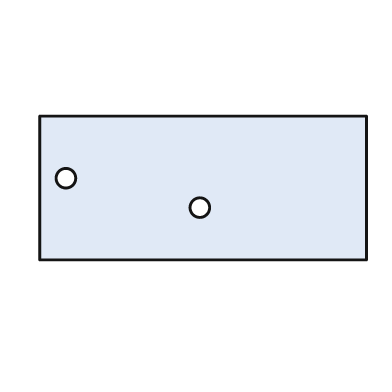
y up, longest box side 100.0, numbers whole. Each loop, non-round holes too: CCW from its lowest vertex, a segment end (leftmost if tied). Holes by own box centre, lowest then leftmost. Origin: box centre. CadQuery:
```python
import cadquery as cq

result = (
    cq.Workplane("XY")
    .moveTo(-50.0, -22.0)
    .lineTo(50.0, -22.0)
    .lineTo(50.0, 22.0)
    .lineTo(-50.0, 22.0)
    .close()
    .moveTo(-1.0, -6.0)
    .circle(3.0)
    .moveTo(-42.0, 3.0)
    .circle(3.0)
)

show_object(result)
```